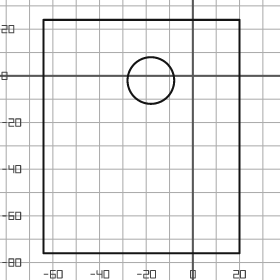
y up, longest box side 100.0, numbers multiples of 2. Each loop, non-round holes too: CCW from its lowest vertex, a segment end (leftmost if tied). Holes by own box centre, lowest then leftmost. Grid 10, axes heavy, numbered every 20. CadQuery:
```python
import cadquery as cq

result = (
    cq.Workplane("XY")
    .moveTo(-64.0, -76.0)
    .lineTo(20.0, -76.0)
    .lineTo(20.0, 24.0)
    .lineTo(-64.0, 24.0)
    .close()
    .moveTo(-18.0, -2.0)
    .circle(10.0)
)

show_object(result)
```